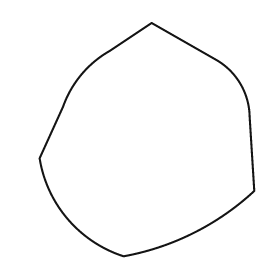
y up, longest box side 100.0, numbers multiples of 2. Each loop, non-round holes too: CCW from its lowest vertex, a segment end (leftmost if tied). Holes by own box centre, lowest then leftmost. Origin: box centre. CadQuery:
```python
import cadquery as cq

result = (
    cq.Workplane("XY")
    .moveTo(-10.0, -50.0)
    .threePointArc((20.0, -40.0), (46.0, -22.0))
    .lineTo(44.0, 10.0)
    .threePointArc((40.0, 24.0), (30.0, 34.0))
    .lineTo(2.0, 50.0)
    .lineTo(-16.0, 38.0)
    .threePointArc((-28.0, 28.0), (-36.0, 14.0))
    .lineTo(-46.0, -8.0)
    .threePointArc((-34.0, -34.0), (-10.0, -50.0))
    .close()
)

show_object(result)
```